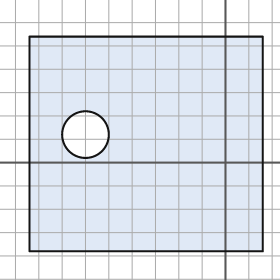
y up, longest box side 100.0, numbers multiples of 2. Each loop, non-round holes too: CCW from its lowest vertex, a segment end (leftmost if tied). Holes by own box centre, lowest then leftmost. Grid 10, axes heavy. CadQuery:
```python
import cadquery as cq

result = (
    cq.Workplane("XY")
    .moveTo(-84.0, -38.0)
    .lineTo(16.0, -38.0)
    .lineTo(16.0, 54.0)
    .lineTo(-84.0, 54.0)
    .close()
    .moveTo(-60.0, 12.0)
    .circle(10.0)
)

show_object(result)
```